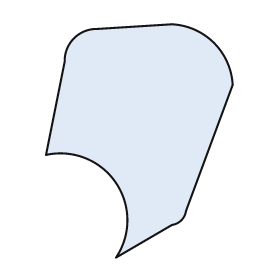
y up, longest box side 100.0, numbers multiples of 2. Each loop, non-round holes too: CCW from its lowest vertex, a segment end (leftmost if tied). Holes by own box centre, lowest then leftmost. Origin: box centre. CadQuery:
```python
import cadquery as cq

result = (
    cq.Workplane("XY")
    .moveTo(-10.0, -50.0)
    .lineTo(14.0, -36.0)
    .threePointArc((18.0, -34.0), (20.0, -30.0))
    .lineTo(40.0, 24.0)
    .threePointArc((32.0, 42.0), (14.0, 50.0))
    .lineTo(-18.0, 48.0)
    .threePointArc((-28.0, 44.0), (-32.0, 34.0))
    .lineTo(-40.0, -6.0)
    .threePointArc((-10.0, -18.0), (-10.0, -50.0))
    .close()
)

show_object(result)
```